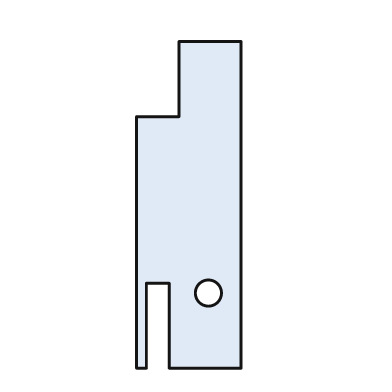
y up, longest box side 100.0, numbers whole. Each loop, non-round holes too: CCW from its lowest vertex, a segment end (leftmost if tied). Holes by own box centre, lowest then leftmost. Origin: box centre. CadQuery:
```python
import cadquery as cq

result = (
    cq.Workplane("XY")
    .moveTo(-16.0, -50.0)
    .lineTo(-13.0, -50.0)
    .lineTo(-13.0, -24.0)
    .lineTo(-6.0, -24.0)
    .lineTo(-6.0, -50.0)
    .lineTo(16.0, -50.0)
    .lineTo(16.0, 50.0)
    .lineTo(-3.0, 50.0)
    .lineTo(-3.0, 27.0)
    .lineTo(-16.0, 27.0)
    .close()
    .moveTo(6.0, -27.0)
    .circle(4.0)
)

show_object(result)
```